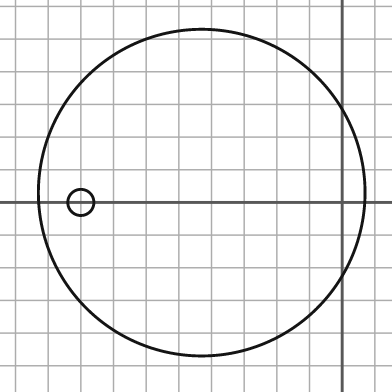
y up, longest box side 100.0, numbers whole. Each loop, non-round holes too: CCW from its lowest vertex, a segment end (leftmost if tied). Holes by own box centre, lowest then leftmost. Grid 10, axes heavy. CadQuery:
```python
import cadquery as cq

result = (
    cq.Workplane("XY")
    .moveTo(-43.0, 3.0)
    .circle(50.0)
    .moveTo(-80.0, 0.0)
    .circle(4.0)
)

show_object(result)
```